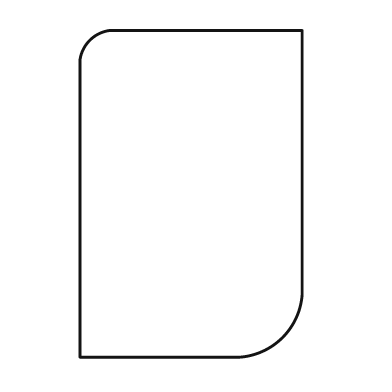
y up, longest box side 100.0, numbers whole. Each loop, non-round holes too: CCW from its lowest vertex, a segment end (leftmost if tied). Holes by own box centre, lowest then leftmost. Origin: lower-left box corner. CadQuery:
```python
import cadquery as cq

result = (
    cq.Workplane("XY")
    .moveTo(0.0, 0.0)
    .lineTo(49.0, 0.0)
    .threePointArc((62.0, 6.0), (68.0, 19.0))
    .lineTo(68.0, 100.0)
    .lineTo(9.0, 100.0)
    .threePointArc((3.0, 97.0), (0.0, 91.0))
    .close()
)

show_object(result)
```